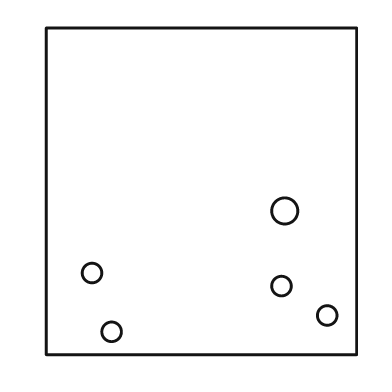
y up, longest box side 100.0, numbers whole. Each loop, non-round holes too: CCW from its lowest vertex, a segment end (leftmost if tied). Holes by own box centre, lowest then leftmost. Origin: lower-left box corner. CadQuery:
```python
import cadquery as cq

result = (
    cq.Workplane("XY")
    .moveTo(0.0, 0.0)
    .lineTo(95.0, 0.0)
    .lineTo(95.0, 100.0)
    .lineTo(0.0, 100.0)
    .close()
    .moveTo(20.0, 7.0)
    .circle(3.0)
    .moveTo(86.0, 12.0)
    .circle(3.0)
    .moveTo(72.0, 21.0)
    .circle(3.0)
    .moveTo(14.0, 25.0)
    .circle(3.0)
    .moveTo(73.0, 44.0)
    .circle(4.0)
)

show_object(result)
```